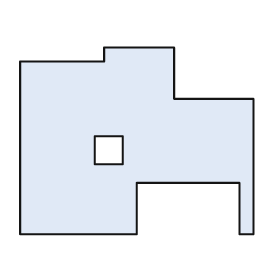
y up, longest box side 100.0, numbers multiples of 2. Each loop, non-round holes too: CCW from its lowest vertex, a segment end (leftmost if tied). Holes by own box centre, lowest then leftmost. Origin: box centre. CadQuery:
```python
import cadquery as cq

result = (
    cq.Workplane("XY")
    .moveTo(-50.0, -40.0)
    .lineTo(0.0, -40.0)
    .lineTo(0.0, -18.0)
    .lineTo(44.0, -18.0)
    .lineTo(44.0, -40.0)
    .lineTo(50.0, -40.0)
    .lineTo(50.0, 18.0)
    .lineTo(16.0, 18.0)
    .lineTo(16.0, 40.0)
    .lineTo(-14.0, 40.0)
    .lineTo(-14.0, 34.0)
    .lineTo(-50.0, 34.0)
    .close()
    .moveTo(-18.0, -10.0)
    .lineTo(-6.0, -10.0)
    .lineTo(-6.0, 2.0)
    .lineTo(-18.0, 2.0)
    .close()
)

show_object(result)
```